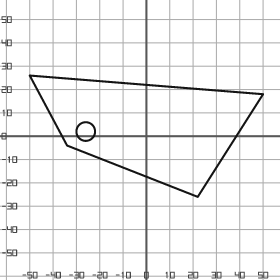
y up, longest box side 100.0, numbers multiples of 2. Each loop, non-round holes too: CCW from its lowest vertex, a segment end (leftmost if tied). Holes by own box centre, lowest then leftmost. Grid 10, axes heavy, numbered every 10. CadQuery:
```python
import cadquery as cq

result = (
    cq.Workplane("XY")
    .moveTo(22.0, -26.0)
    .lineTo(50.0, 18.0)
    .lineTo(-50.0, 26.0)
    .lineTo(-34.0, -4.0)
    .close()
    .moveTo(-26.0, 2.0)
    .circle(4.0)
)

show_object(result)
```